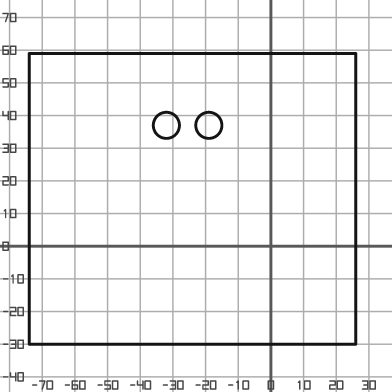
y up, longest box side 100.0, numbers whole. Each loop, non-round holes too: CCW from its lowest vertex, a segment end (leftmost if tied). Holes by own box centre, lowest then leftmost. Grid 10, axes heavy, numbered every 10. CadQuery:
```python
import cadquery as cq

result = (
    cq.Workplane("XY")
    .moveTo(-74.0, -30.0)
    .lineTo(26.0, -30.0)
    .lineTo(26.0, 59.0)
    .lineTo(-74.0, 59.0)
    .close()
    .moveTo(-32.0, 37.0)
    .circle(4.0)
    .moveTo(-19.0, 37.0)
    .circle(4.0)
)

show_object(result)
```